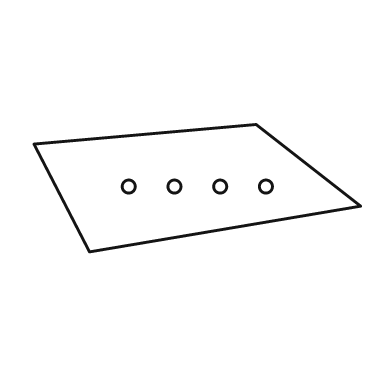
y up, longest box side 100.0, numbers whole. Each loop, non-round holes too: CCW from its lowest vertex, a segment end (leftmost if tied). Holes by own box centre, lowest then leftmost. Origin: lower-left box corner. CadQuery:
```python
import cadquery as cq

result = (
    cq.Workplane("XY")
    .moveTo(17.0, 0.0)
    .lineTo(100.0, 14.0)
    .lineTo(68.0, 39.0)
    .lineTo(0.0, 33.0)
    .close()
    .moveTo(29.0, 20.0)
    .circle(2.0)
    .moveTo(43.0, 20.0)
    .circle(2.0)
    .moveTo(57.0, 20.0)
    .circle(2.0)
    .moveTo(71.0, 20.0)
    .circle(2.0)
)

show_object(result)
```